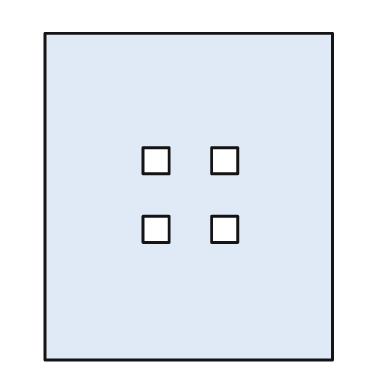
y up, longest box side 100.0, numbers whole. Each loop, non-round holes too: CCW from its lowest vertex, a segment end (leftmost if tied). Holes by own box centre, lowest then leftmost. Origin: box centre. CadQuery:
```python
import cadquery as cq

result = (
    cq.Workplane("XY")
    .moveTo(-44.0, -50.0)
    .lineTo(44.0, -50.0)
    .lineTo(44.0, 50.0)
    .lineTo(-44.0, 50.0)
    .close()
    .moveTo(-14.0, -14.0)
    .lineTo(-6.0, -14.0)
    .lineTo(-6.0, -6.0)
    .lineTo(-14.0, -6.0)
    .close()
    .moveTo(7.0, -14.0)
    .lineTo(15.0, -14.0)
    .lineTo(15.0, -6.0)
    .lineTo(7.0, -6.0)
    .close()
    .moveTo(-14.0, 7.0)
    .lineTo(-6.0, 7.0)
    .lineTo(-6.0, 15.0)
    .lineTo(-14.0, 15.0)
    .close()
    .moveTo(7.0, 7.0)
    .lineTo(15.0, 7.0)
    .lineTo(15.0, 15.0)
    .lineTo(7.0, 15.0)
    .close()
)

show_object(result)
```